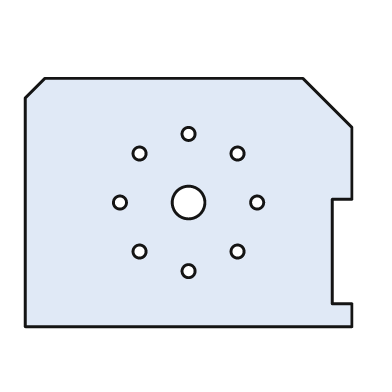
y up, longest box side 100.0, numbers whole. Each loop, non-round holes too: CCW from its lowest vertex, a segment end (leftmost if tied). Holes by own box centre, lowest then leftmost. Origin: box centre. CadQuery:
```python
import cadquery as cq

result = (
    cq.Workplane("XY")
    .moveTo(-50.0, -38.0)
    .lineTo(50.0, -38.0)
    .lineTo(50.0, -31.0)
    .lineTo(44.0, -31.0)
    .lineTo(44.0, 1.0)
    .lineTo(50.0, 1.0)
    .lineTo(50.0, 23.0)
    .lineTo(35.0, 38.0)
    .lineTo(-44.0, 38.0)
    .lineTo(-50.0, 32.0)
    .close()
    .moveTo(0.0, -21.0)
    .circle(2.0)
    .moveTo(-15.0, -15.0)
    .circle(2.0)
    .moveTo(15.0, -15.0)
    .circle(2.0)
    .moveTo(-21.0, 0.0)
    .circle(2.0)
    .moveTo(0.0, 0.0)
    .circle(5.0)
    .moveTo(21.0, 0.0)
    .circle(2.0)
    .moveTo(-15.0, 15.0)
    .circle(2.0)
    .moveTo(15.0, 15.0)
    .circle(2.0)
    .moveTo(0.0, 21.0)
    .circle(2.0)
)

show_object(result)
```